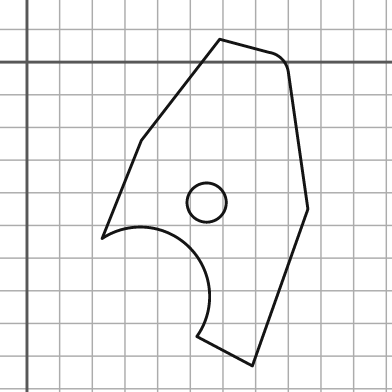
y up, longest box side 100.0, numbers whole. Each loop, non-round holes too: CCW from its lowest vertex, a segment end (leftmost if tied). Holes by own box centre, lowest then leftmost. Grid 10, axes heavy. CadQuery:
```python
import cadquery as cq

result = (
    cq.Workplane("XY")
    .moveTo(69.0, -93.0)
    .lineTo(86.0, -45.0)
    .lineTo(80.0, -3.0)
    .threePointArc((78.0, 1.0), (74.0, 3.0))
    .lineTo(59.0, 7.0)
    .lineTo(35.0, -24.0)
    .lineTo(23.0, -54.0)
    .threePointArc((50.0, -57.0), (52.0, -84.0))
    .close()
    .moveTo(55.0, -43.0)
    .circle(6.0)
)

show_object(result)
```